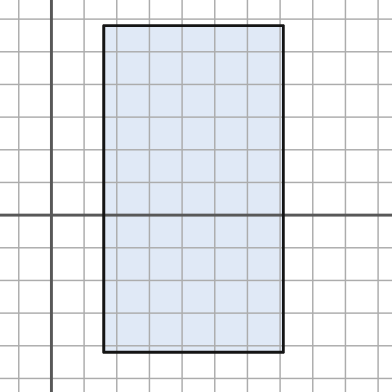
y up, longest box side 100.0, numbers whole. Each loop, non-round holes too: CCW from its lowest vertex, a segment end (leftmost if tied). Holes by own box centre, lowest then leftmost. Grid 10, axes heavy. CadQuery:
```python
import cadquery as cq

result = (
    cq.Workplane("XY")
    .moveTo(16.0, -42.0)
    .lineTo(71.0, -42.0)
    .lineTo(71.0, 58.0)
    .lineTo(16.0, 58.0)
    .close()
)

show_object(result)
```